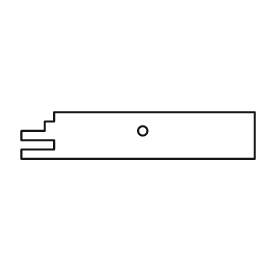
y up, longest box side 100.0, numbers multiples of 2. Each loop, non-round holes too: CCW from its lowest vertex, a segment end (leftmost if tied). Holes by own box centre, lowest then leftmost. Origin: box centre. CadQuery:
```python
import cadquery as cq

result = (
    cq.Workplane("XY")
    .moveTo(-50.0, -10.0)
    .lineTo(50.0, -10.0)
    .lineTo(50.0, 10.0)
    .lineTo(-36.0, 10.0)
    .lineTo(-36.0, 6.0)
    .lineTo(-40.0, 6.0)
    .lineTo(-40.0, 2.0)
    .lineTo(-50.0, 2.0)
    .lineTo(-50.0, -2.0)
    .lineTo(-36.0, -2.0)
    .lineTo(-36.0, -6.0)
    .lineTo(-50.0, -6.0)
    .close()
    .moveTo(2.0, 2.0)
    .circle(2.0)
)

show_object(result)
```